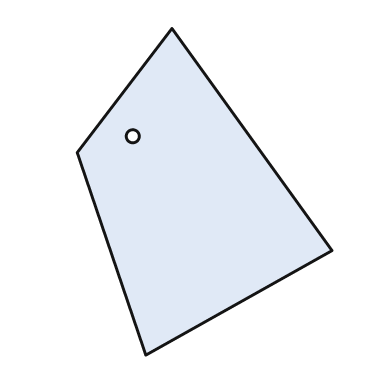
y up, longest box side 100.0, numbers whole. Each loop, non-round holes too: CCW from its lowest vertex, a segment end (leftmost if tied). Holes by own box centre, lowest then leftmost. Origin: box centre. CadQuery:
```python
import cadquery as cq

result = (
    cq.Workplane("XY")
    .moveTo(-18.0, -50.0)
    .lineTo(39.0, -18.0)
    .lineTo(-10.0, 50.0)
    .lineTo(-39.0, 12.0)
    .close()
    .moveTo(-22.0, 17.0)
    .circle(2.0)
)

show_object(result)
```